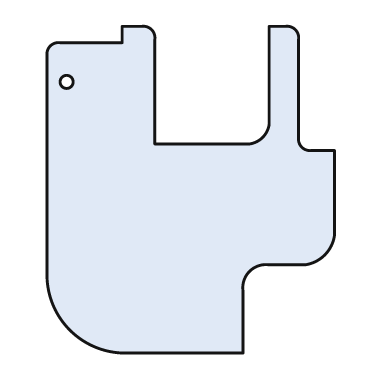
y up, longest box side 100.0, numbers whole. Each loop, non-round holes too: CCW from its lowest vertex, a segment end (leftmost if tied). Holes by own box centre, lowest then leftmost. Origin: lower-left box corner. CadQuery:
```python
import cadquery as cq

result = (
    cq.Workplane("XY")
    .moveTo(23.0, 0.0)
    .lineTo(60.0, 0.0)
    .lineTo(60.0, 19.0)
    .threePointArc((62.0, 25.0), (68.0, 27.0))
    .lineTo(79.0, 27.0)
    .threePointArc((85.0, 30.0), (88.0, 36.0))
    .lineTo(88.0, 62.0)
    .lineTo(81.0, 62.0)
    .threePointArc((78.0, 63.0), (77.0, 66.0))
    .lineTo(77.0, 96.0)
    .threePointArc((76.0, 99.0), (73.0, 100.0))
    .lineTo(68.0, 100.0)
    .lineTo(68.0, 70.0)
    .threePointArc((66.0, 66.0), (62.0, 64.0))
    .lineTo(33.0, 64.0)
    .lineTo(33.0, 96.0)
    .threePointArc((32.0, 99.0), (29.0, 100.0))
    .lineTo(23.0, 100.0)
    .lineTo(23.0, 95.0)
    .lineTo(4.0, 95.0)
    .threePointArc((1.0, 94.0), (0.0, 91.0))
    .lineTo(0.0, 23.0)
    .threePointArc((7.0, 7.0), (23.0, 0.0))
    .close()
    .moveTo(6.0, 83.0)
    .circle(2.0)
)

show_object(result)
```